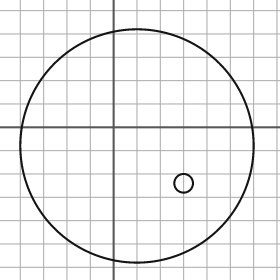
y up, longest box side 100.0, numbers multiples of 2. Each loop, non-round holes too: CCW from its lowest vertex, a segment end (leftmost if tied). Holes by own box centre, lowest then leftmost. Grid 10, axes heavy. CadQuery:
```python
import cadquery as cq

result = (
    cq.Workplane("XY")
    .moveTo(10.0, -8.0)
    .circle(50.0)
    .moveTo(30.0, -24.0)
    .circle(4.0)
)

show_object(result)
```